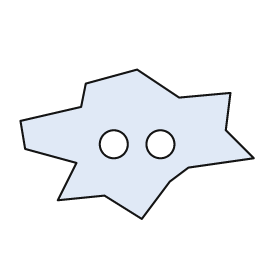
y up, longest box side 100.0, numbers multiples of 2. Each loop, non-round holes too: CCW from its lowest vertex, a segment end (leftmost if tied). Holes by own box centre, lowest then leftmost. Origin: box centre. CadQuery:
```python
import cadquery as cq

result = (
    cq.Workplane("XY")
    .moveTo(2.0, -32.0)
    .lineTo(14.0, -16.0)
    .lineTo(22.0, -10.0)
    .lineTo(50.0, -6.0)
    .lineTo(38.0, 6.0)
    .lineTo(40.0, 22.0)
    .lineTo(18.0, 20.0)
    .lineTo(0.0, 32.0)
    .lineTo(-22.0, 26.0)
    .lineTo(-24.0, 16.0)
    .lineTo(-50.0, 10.0)
    .lineTo(-48.0, -2.0)
    .lineTo(-26.0, -8.0)
    .lineTo(-34.0, -24.0)
    .lineTo(-14.0, -22.0)
    .close()
    .moveTo(-10.0, 0.0)
    .circle(6.0)
    .moveTo(10.0, 0.0)
    .circle(6.0)
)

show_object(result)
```